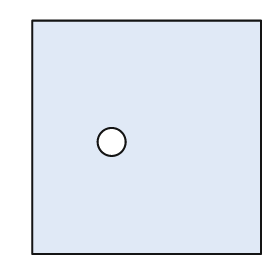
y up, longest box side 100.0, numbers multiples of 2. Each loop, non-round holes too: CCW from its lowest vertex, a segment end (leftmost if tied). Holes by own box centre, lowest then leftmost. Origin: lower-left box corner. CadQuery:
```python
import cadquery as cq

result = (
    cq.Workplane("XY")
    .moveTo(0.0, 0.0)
    .lineTo(98.0, 0.0)
    .lineTo(98.0, 100.0)
    .lineTo(0.0, 100.0)
    .close()
    .moveTo(34.0, 48.0)
    .circle(6.0)
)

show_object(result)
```